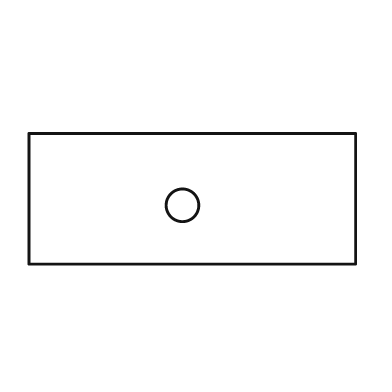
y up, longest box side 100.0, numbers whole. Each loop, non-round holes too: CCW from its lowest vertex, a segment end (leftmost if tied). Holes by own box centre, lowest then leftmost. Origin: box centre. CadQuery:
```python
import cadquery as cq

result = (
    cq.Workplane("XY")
    .moveTo(-50.0, -20.0)
    .lineTo(50.0, -20.0)
    .lineTo(50.0, 20.0)
    .lineTo(-50.0, 20.0)
    .close()
    .moveTo(-3.0, -2.0)
    .circle(5.0)
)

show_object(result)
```